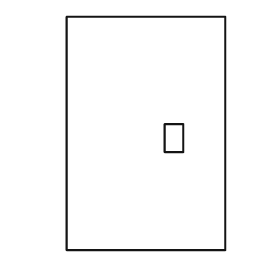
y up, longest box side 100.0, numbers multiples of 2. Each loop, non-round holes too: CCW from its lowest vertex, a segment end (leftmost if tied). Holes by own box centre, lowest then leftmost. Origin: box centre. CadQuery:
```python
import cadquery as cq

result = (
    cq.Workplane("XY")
    .moveTo(-34.0, -50.0)
    .lineTo(34.0, -50.0)
    .lineTo(34.0, 50.0)
    .lineTo(-34.0, 50.0)
    .close()
    .moveTo(8.0, -8.0)
    .lineTo(16.0, -8.0)
    .lineTo(16.0, 4.0)
    .lineTo(8.0, 4.0)
    .close()
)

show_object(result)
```